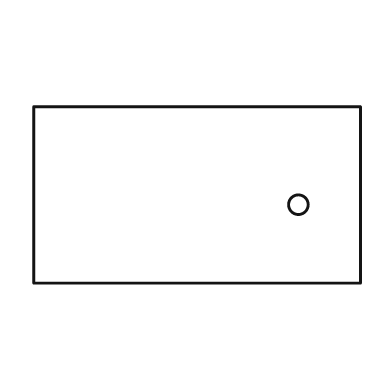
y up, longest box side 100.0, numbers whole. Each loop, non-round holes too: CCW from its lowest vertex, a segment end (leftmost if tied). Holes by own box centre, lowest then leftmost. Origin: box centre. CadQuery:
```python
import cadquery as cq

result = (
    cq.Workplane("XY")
    .moveTo(-50.0, -27.0)
    .lineTo(50.0, -27.0)
    .lineTo(50.0, 27.0)
    .lineTo(-50.0, 27.0)
    .close()
    .moveTo(31.0, -3.0)
    .circle(3.0)
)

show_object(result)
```